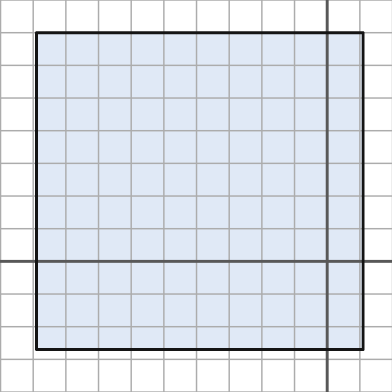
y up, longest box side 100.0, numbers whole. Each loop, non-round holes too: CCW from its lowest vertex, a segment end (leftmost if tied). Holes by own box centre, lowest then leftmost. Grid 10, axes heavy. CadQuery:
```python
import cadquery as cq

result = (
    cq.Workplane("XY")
    .moveTo(-89.0, -27.0)
    .lineTo(11.0, -27.0)
    .lineTo(11.0, 70.0)
    .lineTo(-89.0, 70.0)
    .close()
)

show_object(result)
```